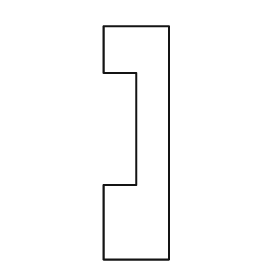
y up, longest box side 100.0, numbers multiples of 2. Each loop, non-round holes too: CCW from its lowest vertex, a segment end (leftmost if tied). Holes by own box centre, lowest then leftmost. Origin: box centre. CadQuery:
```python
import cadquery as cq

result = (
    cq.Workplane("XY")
    .moveTo(-14.0, -50.0)
    .lineTo(14.0, -50.0)
    .lineTo(14.0, 50.0)
    .lineTo(-14.0, 50.0)
    .lineTo(-14.0, 30.0)
    .lineTo(0.0, 30.0)
    .lineTo(0.0, -18.0)
    .lineTo(-14.0, -18.0)
    .close()
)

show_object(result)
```